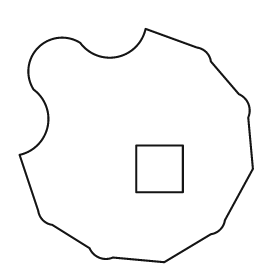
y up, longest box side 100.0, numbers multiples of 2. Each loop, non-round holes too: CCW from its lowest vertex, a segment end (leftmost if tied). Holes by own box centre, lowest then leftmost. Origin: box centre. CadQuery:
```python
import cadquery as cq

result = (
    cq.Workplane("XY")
    .moveTo(12.0, -50.0)
    .lineTo(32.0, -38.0)
    .threePointArc((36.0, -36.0), (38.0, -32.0))
    .lineTo(50.0, -10.0)
    .lineTo(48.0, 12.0)
    .threePointArc((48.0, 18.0), (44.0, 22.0))
    .lineTo(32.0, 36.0)
    .threePointArc((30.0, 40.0), (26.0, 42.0))
    .lineTo(4.0, 50.0)
    .threePointArc((-8.0, 38.0), (-24.0, 44.0))
    .threePointArc((-42.0, 42.0), (-44.0, 24.0))
    .threePointArc((-38.0, 8.0), (-50.0, -4.0))
    .lineTo(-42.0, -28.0)
    .threePointArc((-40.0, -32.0), (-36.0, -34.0))
    .lineTo(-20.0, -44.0)
    .threePointArc((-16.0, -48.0), (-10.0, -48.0))
    .close()
    .moveTo(0.0, -20.0)
    .lineTo(20.0, -20.0)
    .lineTo(20.0, 0.0)
    .lineTo(0.0, 0.0)
    .close()
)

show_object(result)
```